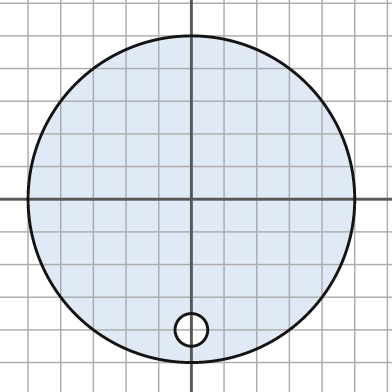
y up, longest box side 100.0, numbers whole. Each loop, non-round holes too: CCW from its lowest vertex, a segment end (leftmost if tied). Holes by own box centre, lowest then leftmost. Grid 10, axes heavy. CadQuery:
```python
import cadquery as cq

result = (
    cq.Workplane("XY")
    .moveTo(0.0, 0.0)
    .circle(50.0)
    .moveTo(0.0, -40.0)
    .circle(5.0)
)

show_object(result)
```